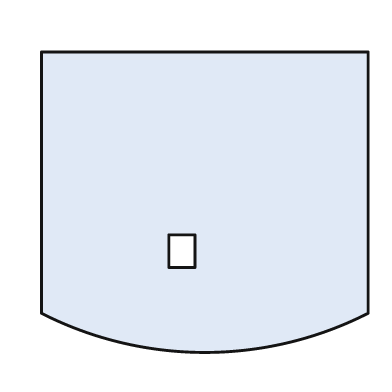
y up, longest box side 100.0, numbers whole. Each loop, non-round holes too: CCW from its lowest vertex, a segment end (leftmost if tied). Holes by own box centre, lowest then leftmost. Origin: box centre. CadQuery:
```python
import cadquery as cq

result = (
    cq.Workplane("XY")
    .moveTo(-50.0, -34.0)
    .threePointArc((0.0, -46.0), (50.0, -34.0))
    .lineTo(50.0, 46.0)
    .lineTo(-50.0, 46.0)
    .close()
    .moveTo(-11.0, -20.0)
    .lineTo(-3.0, -20.0)
    .lineTo(-3.0, -10.0)
    .lineTo(-11.0, -10.0)
    .close()
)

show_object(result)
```